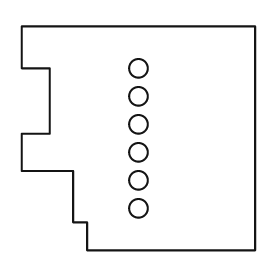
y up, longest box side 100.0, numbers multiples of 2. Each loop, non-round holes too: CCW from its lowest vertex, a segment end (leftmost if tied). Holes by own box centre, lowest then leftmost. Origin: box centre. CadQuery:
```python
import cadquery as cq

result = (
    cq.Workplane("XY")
    .moveTo(-22.0, -48.0)
    .lineTo(50.0, -48.0)
    .lineTo(50.0, 48.0)
    .lineTo(-50.0, 48.0)
    .lineTo(-50.0, 30.0)
    .lineTo(-38.0, 30.0)
    .lineTo(-38.0, 2.0)
    .lineTo(-50.0, 2.0)
    .lineTo(-50.0, -14.0)
    .lineTo(-28.0, -14.0)
    .lineTo(-28.0, -36.0)
    .lineTo(-22.0, -36.0)
    .close()
    .moveTo(0.0, -30.0)
    .circle(4.0)
    .moveTo(0.0, -18.0)
    .circle(4.0)
    .moveTo(0.0, -6.0)
    .circle(4.0)
    .moveTo(0.0, 6.0)
    .circle(4.0)
    .moveTo(0.0, 18.0)
    .circle(4.0)
    .moveTo(0.0, 30.0)
    .circle(4.0)
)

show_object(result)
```